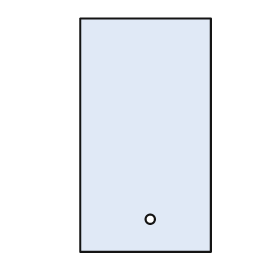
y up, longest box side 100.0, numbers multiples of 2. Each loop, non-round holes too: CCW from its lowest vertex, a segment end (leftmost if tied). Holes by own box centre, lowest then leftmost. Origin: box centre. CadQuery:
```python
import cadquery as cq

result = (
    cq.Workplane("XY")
    .moveTo(-28.0, -50.0)
    .lineTo(28.0, -50.0)
    .lineTo(28.0, 50.0)
    .lineTo(-28.0, 50.0)
    .close()
    .moveTo(2.0, -36.0)
    .circle(2.0)
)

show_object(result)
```